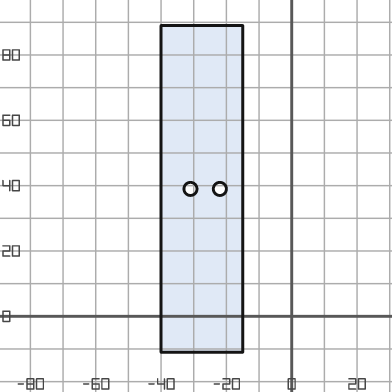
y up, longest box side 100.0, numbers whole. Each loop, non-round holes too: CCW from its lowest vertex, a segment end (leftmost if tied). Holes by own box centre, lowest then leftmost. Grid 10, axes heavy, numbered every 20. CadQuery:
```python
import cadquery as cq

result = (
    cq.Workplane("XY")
    .moveTo(-40.0, -11.0)
    .lineTo(-15.0, -11.0)
    .lineTo(-15.0, 89.0)
    .lineTo(-40.0, 89.0)
    .close()
    .moveTo(-31.0, 39.0)
    .circle(2.0)
    .moveTo(-22.0, 39.0)
    .circle(2.0)
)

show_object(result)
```